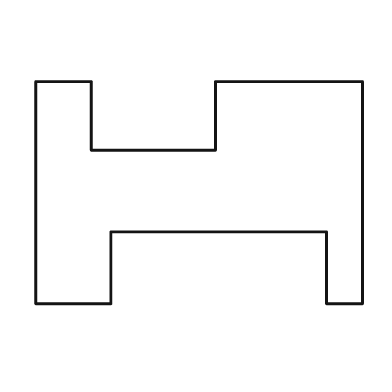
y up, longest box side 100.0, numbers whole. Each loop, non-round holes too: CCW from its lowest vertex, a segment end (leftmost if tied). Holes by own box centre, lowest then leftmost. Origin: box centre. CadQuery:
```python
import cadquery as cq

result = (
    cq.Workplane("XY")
    .moveTo(-50.0, -34.0)
    .lineTo(-27.0, -34.0)
    .lineTo(-27.0, -12.0)
    .lineTo(39.0, -12.0)
    .lineTo(39.0, -34.0)
    .lineTo(50.0, -34.0)
    .lineTo(50.0, 34.0)
    .lineTo(5.0, 34.0)
    .lineTo(5.0, 13.0)
    .lineTo(-33.0, 13.0)
    .lineTo(-33.0, 34.0)
    .lineTo(-50.0, 34.0)
    .close()
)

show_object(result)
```